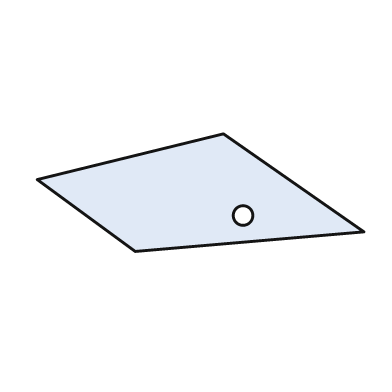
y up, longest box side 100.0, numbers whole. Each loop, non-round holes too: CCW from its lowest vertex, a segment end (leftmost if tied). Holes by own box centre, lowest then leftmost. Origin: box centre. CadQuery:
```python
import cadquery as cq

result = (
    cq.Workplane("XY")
    .moveTo(-20.0, -18.0)
    .lineTo(50.0, -12.0)
    .lineTo(7.0, 18.0)
    .lineTo(-50.0, 4.0)
    .close()
    .moveTo(13.0, -7.0)
    .circle(3.0)
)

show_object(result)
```